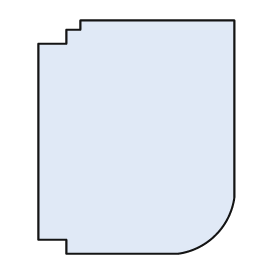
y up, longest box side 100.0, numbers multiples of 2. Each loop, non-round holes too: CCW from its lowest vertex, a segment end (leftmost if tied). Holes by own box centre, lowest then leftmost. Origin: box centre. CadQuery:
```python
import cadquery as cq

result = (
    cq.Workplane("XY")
    .moveTo(-30.0, -50.0)
    .lineTo(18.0, -50.0)
    .threePointArc((34.0, -42.0), (42.0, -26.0))
    .lineTo(42.0, 50.0)
    .lineTo(-24.0, 50.0)
    .lineTo(-24.0, 46.0)
    .lineTo(-30.0, 46.0)
    .lineTo(-30.0, 40.0)
    .lineTo(-42.0, 40.0)
    .lineTo(-42.0, -44.0)
    .lineTo(-30.0, -44.0)
    .close()
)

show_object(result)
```